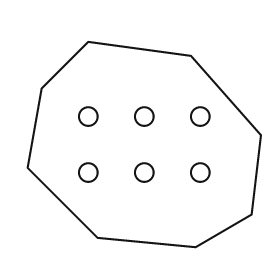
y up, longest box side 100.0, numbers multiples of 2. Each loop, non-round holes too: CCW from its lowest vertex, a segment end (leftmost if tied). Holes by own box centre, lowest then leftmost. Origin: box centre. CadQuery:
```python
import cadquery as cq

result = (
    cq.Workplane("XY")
    .moveTo(22.0, -44.0)
    .lineTo(46.0, -30.0)
    .lineTo(50.0, 4.0)
    .lineTo(20.0, 38.0)
    .lineTo(-24.0, 44.0)
    .lineTo(-44.0, 24.0)
    .lineTo(-50.0, -10.0)
    .lineTo(-20.0, -40.0)
    .close()
    .moveTo(-24.0, -12.0)
    .circle(4.0)
    .moveTo(0.0, -12.0)
    .circle(4.0)
    .moveTo(24.0, -12.0)
    .circle(4.0)
    .moveTo(-24.0, 12.0)
    .circle(4.0)
    .moveTo(0.0, 12.0)
    .circle(4.0)
    .moveTo(24.0, 12.0)
    .circle(4.0)
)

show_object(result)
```